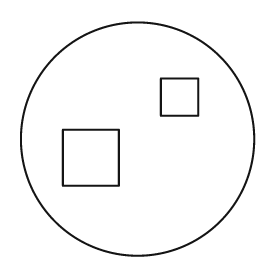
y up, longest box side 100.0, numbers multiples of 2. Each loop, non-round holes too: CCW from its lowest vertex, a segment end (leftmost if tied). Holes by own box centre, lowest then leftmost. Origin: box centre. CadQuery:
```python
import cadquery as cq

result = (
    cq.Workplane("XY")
    .moveTo(0.0, 0.0)
    .circle(50.0)
    .moveTo(-32.0, -20.0)
    .lineTo(-8.0, -20.0)
    .lineTo(-8.0, 4.0)
    .lineTo(-32.0, 4.0)
    .close()
    .moveTo(10.0, 10.0)
    .lineTo(26.0, 10.0)
    .lineTo(26.0, 26.0)
    .lineTo(10.0, 26.0)
    .close()
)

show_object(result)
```